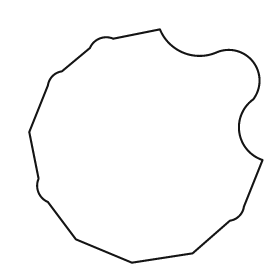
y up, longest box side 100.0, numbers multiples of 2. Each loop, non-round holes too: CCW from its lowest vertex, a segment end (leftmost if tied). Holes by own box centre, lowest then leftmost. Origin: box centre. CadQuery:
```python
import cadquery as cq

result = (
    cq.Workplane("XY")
    .moveTo(-6.0, -50.0)
    .lineTo(20.0, -46.0)
    .lineTo(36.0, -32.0)
    .threePointArc((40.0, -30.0), (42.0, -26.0))
    .lineTo(50.0, -6.0)
    .threePointArc((40.0, 6.0), (46.0, 20.0))
    .threePointArc((46.0, 36.0), (30.0, 40.0))
    .threePointArc((16.0, 40.0), (6.0, 50.0))
    .lineTo(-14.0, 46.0)
    .threePointArc((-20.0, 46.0), (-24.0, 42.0))
    .lineTo(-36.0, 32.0)
    .threePointArc((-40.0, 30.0), (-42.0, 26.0))
    .lineTo(-50.0, 6.0)
    .lineTo(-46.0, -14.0)
    .threePointArc((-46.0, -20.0), (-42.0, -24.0))
    .lineTo(-30.0, -40.0)
    .close()
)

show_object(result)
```